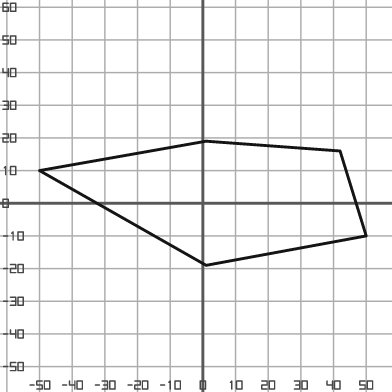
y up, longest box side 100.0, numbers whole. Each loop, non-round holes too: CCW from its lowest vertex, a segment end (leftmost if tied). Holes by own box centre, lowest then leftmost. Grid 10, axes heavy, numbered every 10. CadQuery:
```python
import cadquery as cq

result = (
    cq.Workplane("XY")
    .moveTo(1.0, -19.0)
    .lineTo(50.0, -10.0)
    .lineTo(42.0, 16.0)
    .lineTo(1.0, 19.0)
    .lineTo(-50.0, 10.0)
    .close()
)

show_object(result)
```